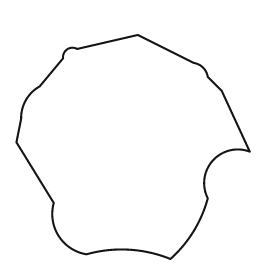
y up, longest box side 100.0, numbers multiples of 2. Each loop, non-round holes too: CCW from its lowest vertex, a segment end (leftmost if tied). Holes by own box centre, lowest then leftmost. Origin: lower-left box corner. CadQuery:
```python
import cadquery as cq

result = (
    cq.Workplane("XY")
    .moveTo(66.0, 0.0)
    .threePointArc((76.0, 12.0), (82.0, 26.0))
    .threePointArc((84.0, 42.0), (100.0, 46.0))
    .lineTo(88.0, 72.0)
    .lineTo(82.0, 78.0)
    .threePointArc((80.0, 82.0), (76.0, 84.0))
    .lineTo(52.0, 96.0)
    .lineTo(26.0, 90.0)
    .threePointArc((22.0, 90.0), (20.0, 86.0))
    .lineTo(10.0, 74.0)
    .threePointArc((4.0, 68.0), (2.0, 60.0))
    .lineTo(0.0, 50.0)
    .lineTo(16.0, 24.0)
    .threePointArc((18.0, 10.0), (30.0, 2.0))
    .threePointArc((48.0, 4.0), (66.0, 0.0))
    .close()
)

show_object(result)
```